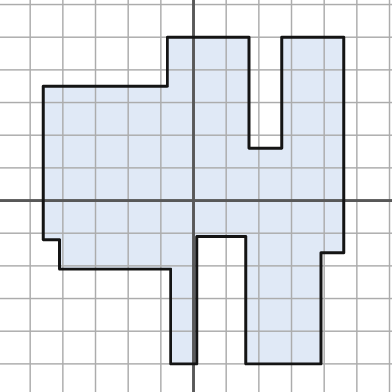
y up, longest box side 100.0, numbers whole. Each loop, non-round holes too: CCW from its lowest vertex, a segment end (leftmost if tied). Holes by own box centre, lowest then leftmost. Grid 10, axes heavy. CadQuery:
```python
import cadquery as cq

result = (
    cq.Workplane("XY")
    .moveTo(-7.0, -50.0)
    .lineTo(1.0, -50.0)
    .lineTo(1.0, -11.0)
    .lineTo(16.0, -11.0)
    .lineTo(16.0, -50.0)
    .lineTo(39.0, -50.0)
    .lineTo(39.0, -16.0)
    .lineTo(46.0, -16.0)
    .lineTo(46.0, 50.0)
    .lineTo(27.0, 50.0)
    .lineTo(27.0, 16.0)
    .lineTo(17.0, 16.0)
    .lineTo(17.0, 50.0)
    .lineTo(-8.0, 50.0)
    .lineTo(-8.0, 35.0)
    .lineTo(-46.0, 35.0)
    .lineTo(-46.0, -12.0)
    .lineTo(-41.0, -12.0)
    .lineTo(-41.0, -21.0)
    .lineTo(-7.0, -21.0)
    .close()
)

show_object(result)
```